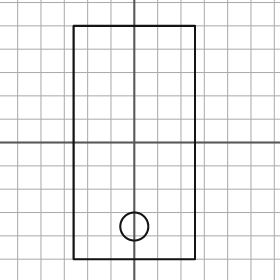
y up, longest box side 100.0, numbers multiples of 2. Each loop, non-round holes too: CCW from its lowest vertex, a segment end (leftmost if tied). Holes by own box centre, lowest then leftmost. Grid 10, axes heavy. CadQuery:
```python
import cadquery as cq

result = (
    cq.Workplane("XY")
    .moveTo(-26.0, -50.0)
    .lineTo(26.0, -50.0)
    .lineTo(26.0, 50.0)
    .lineTo(-26.0, 50.0)
    .close()
    .moveTo(0.0, -36.0)
    .circle(6.0)
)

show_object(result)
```